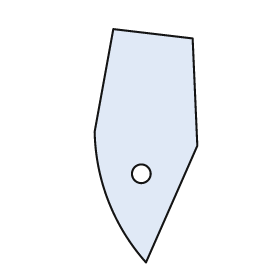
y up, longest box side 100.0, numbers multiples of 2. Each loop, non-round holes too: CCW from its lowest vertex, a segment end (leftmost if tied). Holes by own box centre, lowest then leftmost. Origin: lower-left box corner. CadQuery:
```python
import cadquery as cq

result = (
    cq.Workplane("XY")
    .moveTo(22.0, 0.0)
    .lineTo(44.0, 50.0)
    .lineTo(42.0, 96.0)
    .lineTo(8.0, 100.0)
    .lineTo(0.0, 56.0)
    .threePointArc((6.0, 26.0), (22.0, 0.0))
    .close()
    .moveTo(20.0, 38.0)
    .circle(4.0)
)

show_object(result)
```